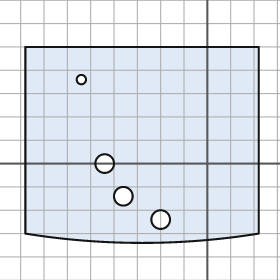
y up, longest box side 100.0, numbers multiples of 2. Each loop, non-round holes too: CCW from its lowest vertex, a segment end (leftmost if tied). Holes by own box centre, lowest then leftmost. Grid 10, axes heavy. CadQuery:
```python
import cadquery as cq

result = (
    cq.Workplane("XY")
    .moveTo(-78.0, -30.0)
    .threePointArc((-28.0, -34.0), (22.0, -30.0))
    .lineTo(22.0, 50.0)
    .lineTo(-78.0, 50.0)
    .close()
    .moveTo(-20.0, -24.0)
    .circle(4.0)
    .moveTo(-36.0, -14.0)
    .circle(4.0)
    .moveTo(-44.0, 0.0)
    .circle(4.0)
    .moveTo(-54.0, 36.0)
    .circle(2.0)
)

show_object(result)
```